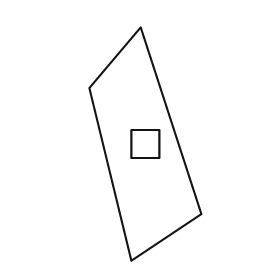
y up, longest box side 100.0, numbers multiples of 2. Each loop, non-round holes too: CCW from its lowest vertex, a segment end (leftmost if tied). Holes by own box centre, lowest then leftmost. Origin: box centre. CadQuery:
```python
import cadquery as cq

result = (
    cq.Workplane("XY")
    .moveTo(-6.0, -50.0)
    .lineTo(24.0, -30.0)
    .lineTo(-2.0, 50.0)
    .lineTo(-24.0, 24.0)
    .close()
    .moveTo(-6.0, -6.0)
    .lineTo(6.0, -6.0)
    .lineTo(6.0, 6.0)
    .lineTo(-6.0, 6.0)
    .close()
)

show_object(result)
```